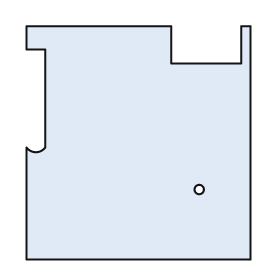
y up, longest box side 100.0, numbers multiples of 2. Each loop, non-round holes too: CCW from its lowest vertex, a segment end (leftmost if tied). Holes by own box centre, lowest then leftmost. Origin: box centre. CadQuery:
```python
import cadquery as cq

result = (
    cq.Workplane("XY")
    .moveTo(-48.0, -50.0)
    .lineTo(48.0, -50.0)
    .lineTo(48.0, 50.0)
    .lineTo(44.0, 50.0)
    .lineTo(44.0, 34.0)
    .lineTo(14.0, 34.0)
    .lineTo(14.0, 50.0)
    .lineTo(-48.0, 50.0)
    .lineTo(-48.0, 40.0)
    .lineTo(-40.0, 40.0)
    .lineTo(-40.0, -2.0)
    .threePointArc((-44.0, -4.0), (-48.0, -2.0))
    .close()
    .moveTo(26.0, -20.0)
    .circle(2.0)
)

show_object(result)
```